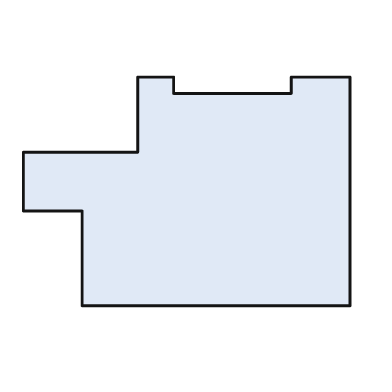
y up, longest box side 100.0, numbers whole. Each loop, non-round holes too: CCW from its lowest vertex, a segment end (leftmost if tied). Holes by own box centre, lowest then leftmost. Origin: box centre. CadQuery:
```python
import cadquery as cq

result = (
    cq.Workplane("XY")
    .moveTo(-32.0, -35.0)
    .lineTo(50.0, -35.0)
    .lineTo(50.0, 35.0)
    .lineTo(32.0, 35.0)
    .lineTo(32.0, 30.0)
    .lineTo(-4.0, 30.0)
    .lineTo(-4.0, 35.0)
    .lineTo(-15.0, 35.0)
    .lineTo(-15.0, 12.0)
    .lineTo(-50.0, 12.0)
    .lineTo(-50.0, -6.0)
    .lineTo(-32.0, -6.0)
    .close()
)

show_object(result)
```